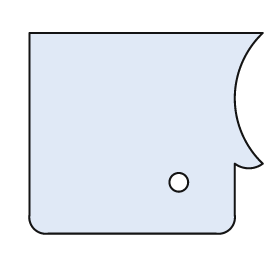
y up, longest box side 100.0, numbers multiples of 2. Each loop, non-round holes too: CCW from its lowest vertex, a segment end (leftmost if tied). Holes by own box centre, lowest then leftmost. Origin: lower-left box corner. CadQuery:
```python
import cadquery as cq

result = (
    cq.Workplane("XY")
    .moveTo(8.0, 0.0)
    .lineTo(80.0, 0.0)
    .threePointArc((86.0, 2.0), (88.0, 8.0))
    .lineTo(88.0, 30.0)
    .threePointArc((94.0, 28.0), (100.0, 30.0))
    .threePointArc((88.0, 58.0), (100.0, 86.0))
    .lineTo(0.0, 86.0)
    .lineTo(0.0, 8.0)
    .threePointArc((2.0, 2.0), (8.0, 0.0))
    .close()
    .moveTo(64.0, 22.0)
    .circle(4.0)
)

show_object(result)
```